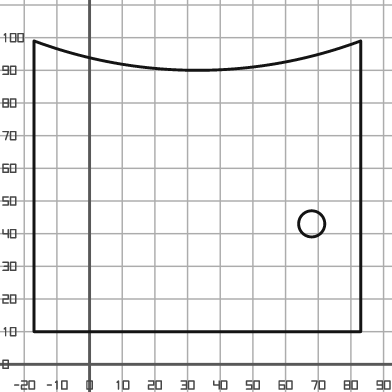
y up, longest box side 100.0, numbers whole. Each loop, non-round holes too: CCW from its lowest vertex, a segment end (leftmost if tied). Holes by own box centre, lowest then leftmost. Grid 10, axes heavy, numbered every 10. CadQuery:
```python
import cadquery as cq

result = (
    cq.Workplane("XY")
    .moveTo(-17.0, 10.0)
    .lineTo(83.0, 10.0)
    .lineTo(83.0, 99.0)
    .threePointArc((33.0, 90.0), (-17.0, 99.0))
    .close()
    .moveTo(68.0, 43.0)
    .circle(4.0)
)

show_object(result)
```